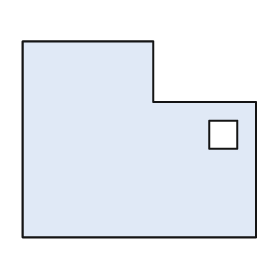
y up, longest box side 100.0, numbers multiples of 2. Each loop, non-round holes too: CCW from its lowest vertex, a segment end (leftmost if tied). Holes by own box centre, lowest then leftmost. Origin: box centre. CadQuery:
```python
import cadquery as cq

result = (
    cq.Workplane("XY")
    .moveTo(-50.0, -42.0)
    .lineTo(50.0, -42.0)
    .lineTo(50.0, 16.0)
    .lineTo(6.0, 16.0)
    .lineTo(6.0, 42.0)
    .lineTo(-50.0, 42.0)
    .close()
    .moveTo(30.0, -4.0)
    .lineTo(42.0, -4.0)
    .lineTo(42.0, 8.0)
    .lineTo(30.0, 8.0)
    .close()
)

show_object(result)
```